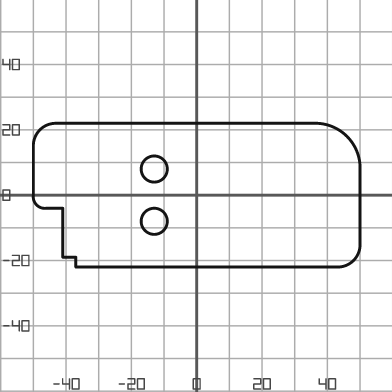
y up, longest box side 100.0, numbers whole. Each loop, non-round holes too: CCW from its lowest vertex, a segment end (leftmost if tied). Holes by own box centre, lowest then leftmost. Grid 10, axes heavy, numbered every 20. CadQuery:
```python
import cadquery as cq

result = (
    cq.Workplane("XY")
    .moveTo(-37.0, -22.0)
    .lineTo(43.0, -22.0)
    .threePointArc((48.0, -20.0), (50.0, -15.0))
    .lineTo(50.0, 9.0)
    .threePointArc((46.0, 18.0), (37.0, 22.0))
    .lineTo(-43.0, 22.0)
    .threePointArc((-48.0, 20.0), (-50.0, 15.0))
    .lineTo(-50.0, 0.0)
    .threePointArc((-49.0, -3.0), (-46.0, -4.0))
    .lineTo(-41.0, -4.0)
    .lineTo(-41.0, -19.0)
    .lineTo(-37.0, -19.0)
    .close()
    .moveTo(-13.0, -8.0)
    .circle(4.0)
    .moveTo(-13.0, 8.0)
    .circle(4.0)
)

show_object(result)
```